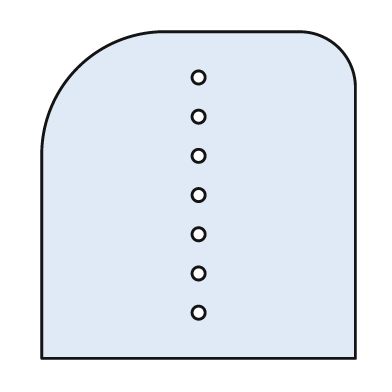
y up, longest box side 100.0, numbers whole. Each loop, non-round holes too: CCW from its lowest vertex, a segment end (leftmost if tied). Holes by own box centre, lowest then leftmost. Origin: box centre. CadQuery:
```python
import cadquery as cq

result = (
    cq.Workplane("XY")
    .moveTo(-48.0, -50.0)
    .lineTo(48.0, -50.0)
    .lineTo(48.0, 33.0)
    .threePointArc((43.0, 45.0), (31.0, 50.0))
    .lineTo(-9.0, 50.0)
    .threePointArc((-37.0, 39.0), (-48.0, 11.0))
    .close()
    .moveTo(0.0, -36.0)
    .circle(2.0)
    .moveTo(0.0, -24.0)
    .circle(2.0)
    .moveTo(0.0, -12.0)
    .circle(2.0)
    .moveTo(0.0, 0.0)
    .circle(2.0)
    .moveTo(0.0, 12.0)
    .circle(2.0)
    .moveTo(0.0, 24.0)
    .circle(2.0)
    .moveTo(0.0, 36.0)
    .circle(2.0)
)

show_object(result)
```